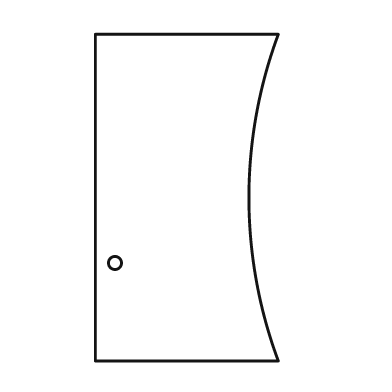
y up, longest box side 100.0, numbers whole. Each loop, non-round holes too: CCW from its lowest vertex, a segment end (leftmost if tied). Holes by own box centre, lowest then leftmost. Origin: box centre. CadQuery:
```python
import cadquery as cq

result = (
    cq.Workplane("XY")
    .moveTo(-28.0, -50.0)
    .lineTo(28.0, -50.0)
    .threePointArc((19.0, 0.0), (28.0, 50.0))
    .lineTo(-28.0, 50.0)
    .close()
    .moveTo(-22.0, -20.0)
    .circle(2.0)
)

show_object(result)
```